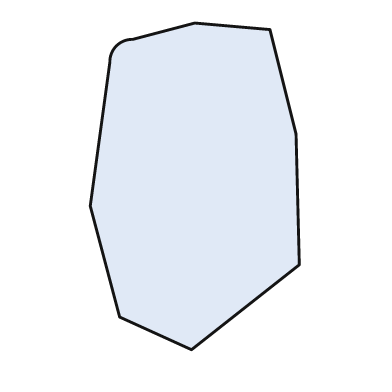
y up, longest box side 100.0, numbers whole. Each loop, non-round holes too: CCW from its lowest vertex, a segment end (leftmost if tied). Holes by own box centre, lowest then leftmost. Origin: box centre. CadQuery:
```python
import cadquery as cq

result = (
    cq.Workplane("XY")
    .moveTo(-1.0, -50.0)
    .lineTo(32.0, -24.0)
    .lineTo(31.0, 16.0)
    .lineTo(23.0, 48.0)
    .lineTo(0.0, 50.0)
    .lineTo(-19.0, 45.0)
    .threePointArc((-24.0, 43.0), (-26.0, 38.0))
    .lineTo(-32.0, -6.0)
    .lineTo(-23.0, -40.0)
    .close()
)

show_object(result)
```